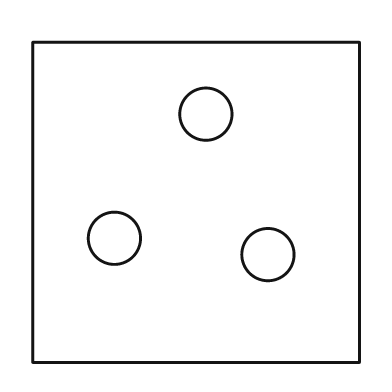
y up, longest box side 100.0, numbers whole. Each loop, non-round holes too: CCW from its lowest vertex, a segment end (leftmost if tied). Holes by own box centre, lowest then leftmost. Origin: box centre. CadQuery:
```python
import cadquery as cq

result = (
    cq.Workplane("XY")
    .moveTo(-50.0, -49.0)
    .lineTo(50.0, -49.0)
    .lineTo(50.0, 49.0)
    .lineTo(-50.0, 49.0)
    .close()
    .moveTo(22.0, -16.0)
    .circle(8.0)
    .moveTo(-25.0, -11.0)
    .circle(8.0)
    .moveTo(3.0, 27.0)
    .circle(8.0)
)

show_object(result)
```